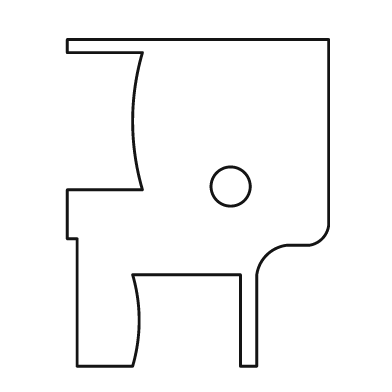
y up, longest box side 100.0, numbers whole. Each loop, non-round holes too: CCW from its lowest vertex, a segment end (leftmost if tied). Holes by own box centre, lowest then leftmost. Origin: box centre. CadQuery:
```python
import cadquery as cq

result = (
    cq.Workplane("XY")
    .moveTo(-37.0, -50.0)
    .lineTo(-20.0, -50.0)
    .threePointArc((-18.0, -36.0), (-20.0, -22.0))
    .lineTo(13.0, -22.0)
    .lineTo(13.0, -50.0)
    .lineTo(18.0, -50.0)
    .lineTo(18.0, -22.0)
    .threePointArc((21.0, -16.0), (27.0, -13.0))
    .lineTo(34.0, -13.0)
    .threePointArc((38.0, -11.0), (40.0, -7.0))
    .lineTo(40.0, 50.0)
    .lineTo(-40.0, 50.0)
    .lineTo(-40.0, 46.0)
    .lineTo(-17.0, 46.0)
    .threePointArc((-20.0, 25.0), (-17.0, 4.0))
    .lineTo(-40.0, 4.0)
    .lineTo(-40.0, -11.0)
    .lineTo(-37.0, -11.0)
    .close()
    .moveTo(10.0, 5.0)
    .circle(6.0)
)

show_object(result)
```